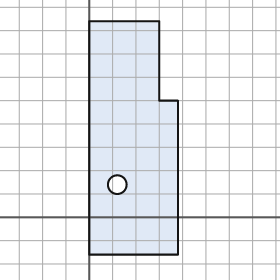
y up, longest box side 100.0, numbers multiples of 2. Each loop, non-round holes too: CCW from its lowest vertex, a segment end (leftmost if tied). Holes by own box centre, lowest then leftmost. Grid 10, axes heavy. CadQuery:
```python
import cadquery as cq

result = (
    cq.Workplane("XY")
    .moveTo(0.0, -16.0)
    .lineTo(38.0, -16.0)
    .lineTo(38.0, 50.0)
    .lineTo(30.0, 50.0)
    .lineTo(30.0, 84.0)
    .lineTo(0.0, 84.0)
    .close()
    .moveTo(12.0, 14.0)
    .circle(4.0)
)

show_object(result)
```